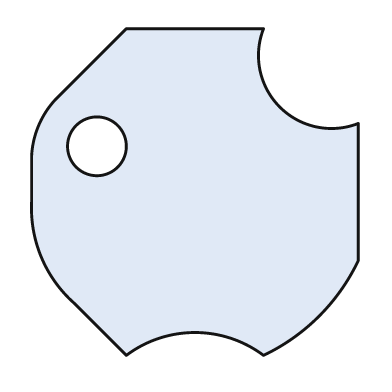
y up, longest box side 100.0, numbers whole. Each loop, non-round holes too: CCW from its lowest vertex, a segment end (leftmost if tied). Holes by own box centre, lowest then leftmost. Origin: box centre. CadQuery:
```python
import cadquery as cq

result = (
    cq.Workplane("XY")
    .moveTo(-21.0, -50.0)
    .threePointArc((0.0, -43.0), (21.0, -50.0))
    .threePointArc((38.0, -38.0), (50.0, -21.0))
    .lineTo(50.0, 21.0)
    .threePointArc((26.0, 26.0), (21.0, 50.0))
    .lineTo(-21.0, 50.0)
    .lineTo(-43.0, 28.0)
    .threePointArc((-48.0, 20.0), (-50.0, 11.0))
    .lineTo(-50.0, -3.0)
    .threePointArc((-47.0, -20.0), (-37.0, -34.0))
    .close()
    .moveTo(-30.0, 14.0)
    .circle(9.0)
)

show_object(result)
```